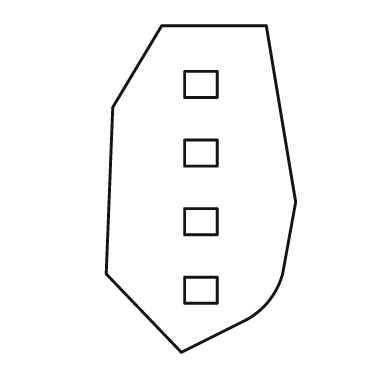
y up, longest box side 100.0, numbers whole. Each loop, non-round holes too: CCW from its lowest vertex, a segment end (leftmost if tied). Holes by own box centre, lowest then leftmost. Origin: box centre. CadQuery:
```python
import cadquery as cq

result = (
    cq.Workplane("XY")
    .moveTo(-6.0, -50.0)
    .lineTo(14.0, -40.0)
    .threePointArc((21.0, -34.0), (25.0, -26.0))
    .lineTo(29.0, -4.0)
    .lineTo(20.0, 50.0)
    .lineTo(-12.0, 50.0)
    .lineTo(-27.0, 25.0)
    .lineTo(-29.0, -26.0)
    .close()
    .moveTo(-5.0, -35.0)
    .lineTo(5.0, -35.0)
    .lineTo(5.0, -27.0)
    .lineTo(-5.0, -27.0)
    .close()
    .moveTo(-5.0, -14.0)
    .lineTo(5.0, -14.0)
    .lineTo(5.0, -6.0)
    .lineTo(-5.0, -6.0)
    .close()
    .moveTo(-5.0, 7.0)
    .lineTo(5.0, 7.0)
    .lineTo(5.0, 15.0)
    .lineTo(-5.0, 15.0)
    .close()
    .moveTo(-5.0, 28.0)
    .lineTo(5.0, 28.0)
    .lineTo(5.0, 36.0)
    .lineTo(-5.0, 36.0)
    .close()
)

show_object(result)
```